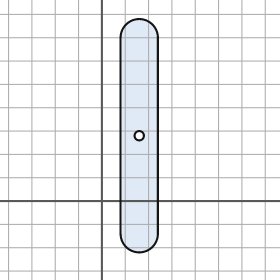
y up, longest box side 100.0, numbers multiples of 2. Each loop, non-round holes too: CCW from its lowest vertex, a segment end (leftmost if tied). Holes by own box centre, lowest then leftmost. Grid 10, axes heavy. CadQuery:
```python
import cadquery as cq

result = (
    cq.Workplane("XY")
    .moveTo(8.0, -14.0)
    .threePointArc((16.0, -22.0), (24.0, -14.0))
    .lineTo(24.0, 70.0)
    .threePointArc((16.0, 78.0), (8.0, 70.0))
    .close()
    .moveTo(16.0, 28.0)
    .circle(2.0)
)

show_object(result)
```